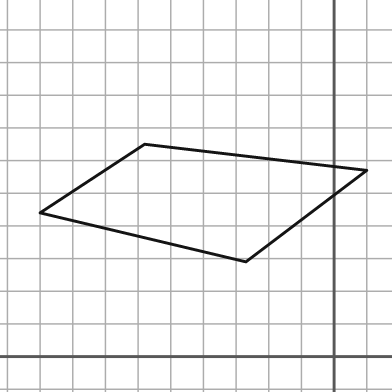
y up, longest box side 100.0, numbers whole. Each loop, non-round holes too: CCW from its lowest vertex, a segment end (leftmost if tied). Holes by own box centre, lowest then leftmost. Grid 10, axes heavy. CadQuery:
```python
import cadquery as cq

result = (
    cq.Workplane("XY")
    .moveTo(-27.0, 29.0)
    .lineTo(10.0, 57.0)
    .lineTo(-58.0, 65.0)
    .lineTo(-90.0, 44.0)
    .close()
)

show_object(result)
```